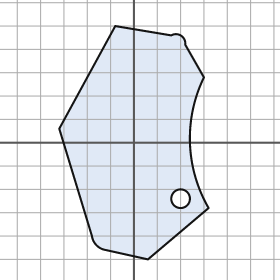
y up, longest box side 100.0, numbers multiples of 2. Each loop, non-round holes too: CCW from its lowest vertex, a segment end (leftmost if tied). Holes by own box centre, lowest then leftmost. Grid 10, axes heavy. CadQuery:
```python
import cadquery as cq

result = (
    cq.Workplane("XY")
    .moveTo(6.0, -50.0)
    .lineTo(32.0, -28.0)
    .threePointArc((24.0, 0.0), (30.0, 28.0))
    .lineTo(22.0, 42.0)
    .threePointArc((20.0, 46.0), (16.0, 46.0))
    .lineTo(-8.0, 50.0)
    .lineTo(-32.0, 6.0)
    .lineTo(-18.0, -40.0)
    .threePointArc((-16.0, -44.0), (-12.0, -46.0))
    .close()
    .moveTo(20.0, -24.0)
    .circle(4.0)
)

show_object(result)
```